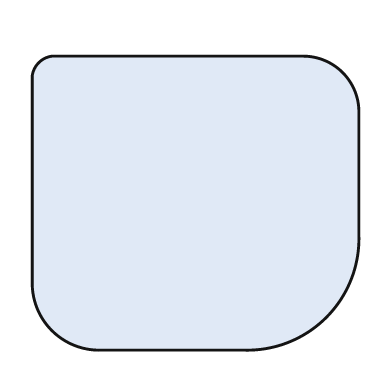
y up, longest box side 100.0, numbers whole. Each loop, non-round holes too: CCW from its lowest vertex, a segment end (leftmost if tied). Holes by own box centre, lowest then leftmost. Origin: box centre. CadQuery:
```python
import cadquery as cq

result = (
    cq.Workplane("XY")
    .moveTo(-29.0, -45.0)
    .lineTo(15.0, -45.0)
    .threePointArc((40.0, -35.0), (50.0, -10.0))
    .lineTo(50.0, 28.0)
    .threePointArc((45.0, 40.0), (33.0, 45.0))
    .lineTo(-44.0, 45.0)
    .threePointArc((-48.0, 43.0), (-50.0, 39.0))
    .lineTo(-50.0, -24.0)
    .threePointArc((-44.0, -39.0), (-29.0, -45.0))
    .close()
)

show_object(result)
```